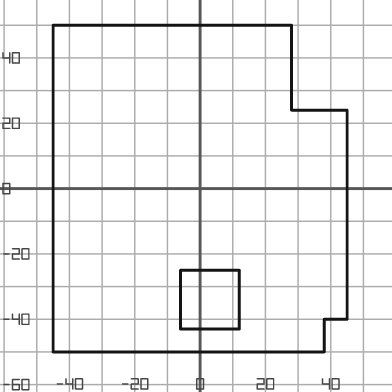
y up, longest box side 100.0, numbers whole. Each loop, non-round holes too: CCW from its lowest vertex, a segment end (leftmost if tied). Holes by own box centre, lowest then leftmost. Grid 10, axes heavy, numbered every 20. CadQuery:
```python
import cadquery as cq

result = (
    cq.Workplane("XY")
    .moveTo(-45.0, -50.0)
    .lineTo(38.0, -50.0)
    .lineTo(38.0, -40.0)
    .lineTo(45.0, -40.0)
    .lineTo(45.0, 24.0)
    .lineTo(28.0, 24.0)
    .lineTo(28.0, 50.0)
    .lineTo(-45.0, 50.0)
    .close()
    .moveTo(-6.0, -43.0)
    .lineTo(12.0, -43.0)
    .lineTo(12.0, -25.0)
    .lineTo(-6.0, -25.0)
    .close()
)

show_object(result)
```